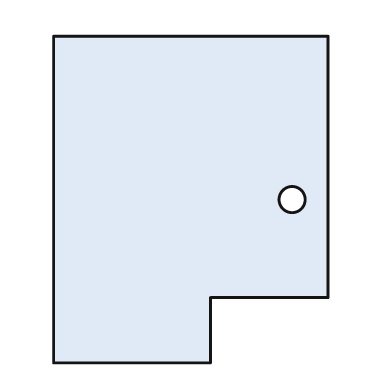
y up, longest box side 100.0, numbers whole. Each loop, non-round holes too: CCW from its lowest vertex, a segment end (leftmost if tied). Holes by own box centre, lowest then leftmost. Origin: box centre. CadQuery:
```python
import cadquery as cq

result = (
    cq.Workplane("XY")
    .moveTo(-42.0, -50.0)
    .lineTo(6.0, -50.0)
    .lineTo(6.0, -30.0)
    .lineTo(42.0, -30.0)
    .lineTo(42.0, 50.0)
    .lineTo(-42.0, 50.0)
    .close()
    .moveTo(31.0, 0.0)
    .circle(4.0)
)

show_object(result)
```